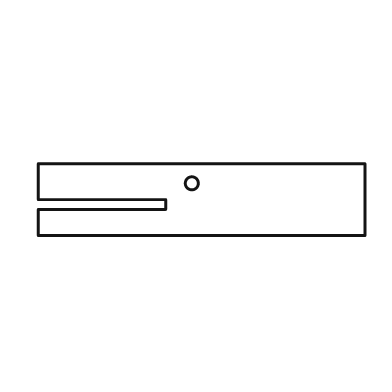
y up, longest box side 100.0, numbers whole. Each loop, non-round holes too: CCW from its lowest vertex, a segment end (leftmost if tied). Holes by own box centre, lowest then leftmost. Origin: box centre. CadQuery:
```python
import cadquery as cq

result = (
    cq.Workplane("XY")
    .moveTo(-50.0, -11.0)
    .lineTo(50.0, -11.0)
    .lineTo(50.0, 11.0)
    .lineTo(-50.0, 11.0)
    .lineTo(-50.0, 0.0)
    .lineTo(-11.0, 0.0)
    .lineTo(-11.0, -3.0)
    .lineTo(-50.0, -3.0)
    .close()
    .moveTo(-3.0, 5.0)
    .circle(2.0)
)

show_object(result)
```